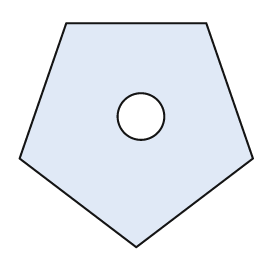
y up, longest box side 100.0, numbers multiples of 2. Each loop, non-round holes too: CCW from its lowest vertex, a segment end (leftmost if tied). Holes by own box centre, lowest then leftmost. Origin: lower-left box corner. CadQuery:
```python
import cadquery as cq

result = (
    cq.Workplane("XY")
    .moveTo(50.0, 0.0)
    .lineTo(100.0, 38.0)
    .lineTo(80.0, 96.0)
    .lineTo(20.0, 96.0)
    .lineTo(0.0, 38.0)
    .close()
    .moveTo(52.0, 56.0)
    .circle(10.0)
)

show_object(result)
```